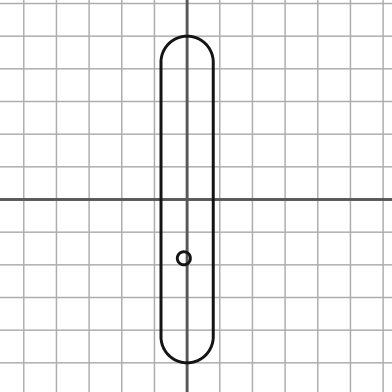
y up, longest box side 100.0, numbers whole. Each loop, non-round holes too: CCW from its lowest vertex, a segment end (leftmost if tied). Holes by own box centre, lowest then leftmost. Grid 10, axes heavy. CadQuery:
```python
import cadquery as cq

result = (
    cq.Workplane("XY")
    .moveTo(-8.0, -42.0)
    .threePointArc((0.0, -50.0), (8.0, -42.0))
    .lineTo(8.0, 42.0)
    .threePointArc((0.0, 50.0), (-8.0, 42.0))
    .close()
    .moveTo(-1.0, -18.0)
    .circle(2.0)
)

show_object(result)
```